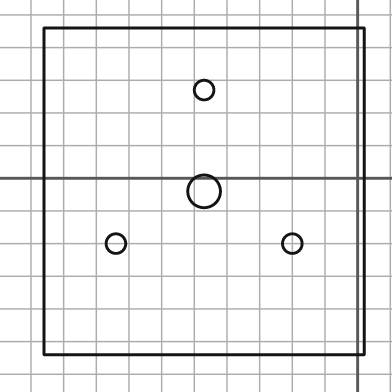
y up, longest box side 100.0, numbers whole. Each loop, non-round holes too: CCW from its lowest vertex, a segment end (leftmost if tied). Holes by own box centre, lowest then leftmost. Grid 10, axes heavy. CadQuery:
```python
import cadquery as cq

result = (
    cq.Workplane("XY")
    .moveTo(-96.0, -54.0)
    .lineTo(2.0, -54.0)
    .lineTo(2.0, 46.0)
    .lineTo(-96.0, 46.0)
    .close()
    .moveTo(-74.0, -20.0)
    .circle(3.0)
    .moveTo(-20.0, -20.0)
    .circle(3.0)
    .moveTo(-47.0, -4.0)
    .circle(5.0)
    .moveTo(-47.0, 27.0)
    .circle(3.0)
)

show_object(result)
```